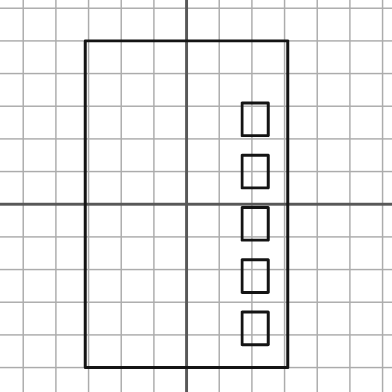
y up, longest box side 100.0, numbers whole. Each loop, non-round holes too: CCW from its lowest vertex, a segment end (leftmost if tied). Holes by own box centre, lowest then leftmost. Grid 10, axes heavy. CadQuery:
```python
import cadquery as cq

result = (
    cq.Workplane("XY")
    .moveTo(-31.0, -50.0)
    .lineTo(31.0, -50.0)
    .lineTo(31.0, 50.0)
    .lineTo(-31.0, 50.0)
    .close()
    .moveTo(17.0, -43.0)
    .lineTo(25.0, -43.0)
    .lineTo(25.0, -33.0)
    .lineTo(17.0, -33.0)
    .close()
    .moveTo(17.0, -27.0)
    .lineTo(25.0, -27.0)
    .lineTo(25.0, -17.0)
    .lineTo(17.0, -17.0)
    .close()
    .moveTo(17.0, -11.0)
    .lineTo(25.0, -11.0)
    .lineTo(25.0, -1.0)
    .lineTo(17.0, -1.0)
    .close()
    .moveTo(17.0, 5.0)
    .lineTo(25.0, 5.0)
    .lineTo(25.0, 15.0)
    .lineTo(17.0, 15.0)
    .close()
    .moveTo(17.0, 21.0)
    .lineTo(25.0, 21.0)
    .lineTo(25.0, 31.0)
    .lineTo(17.0, 31.0)
    .close()
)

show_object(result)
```